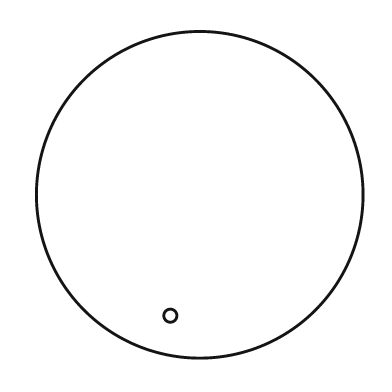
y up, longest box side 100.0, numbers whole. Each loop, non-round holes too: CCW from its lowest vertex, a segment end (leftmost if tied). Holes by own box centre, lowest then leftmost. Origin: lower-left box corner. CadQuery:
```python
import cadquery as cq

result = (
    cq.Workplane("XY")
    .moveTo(50.0, 50.0)
    .circle(50.0)
    .moveTo(41.0, 13.0)
    .circle(2.0)
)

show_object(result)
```